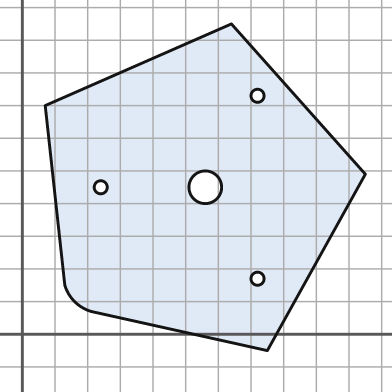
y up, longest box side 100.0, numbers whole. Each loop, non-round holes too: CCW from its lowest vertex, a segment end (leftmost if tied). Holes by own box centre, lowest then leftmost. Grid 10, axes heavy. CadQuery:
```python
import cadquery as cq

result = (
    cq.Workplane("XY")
    .moveTo(75.0, -5.0)
    .lineTo(105.0, 49.0)
    .lineTo(64.0, 95.0)
    .lineTo(7.0, 70.0)
    .lineTo(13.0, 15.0)
    .threePointArc((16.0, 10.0), (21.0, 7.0))
    .close()
    .moveTo(72.0, 17.0)
    .circle(2.0)
    .moveTo(24.0, 45.0)
    .circle(2.0)
    .moveTo(56.0, 45.0)
    .circle(5.0)
    .moveTo(72.0, 73.0)
    .circle(2.0)
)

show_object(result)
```